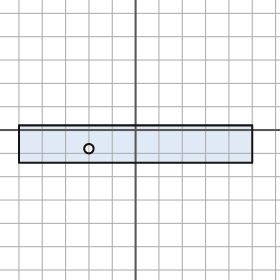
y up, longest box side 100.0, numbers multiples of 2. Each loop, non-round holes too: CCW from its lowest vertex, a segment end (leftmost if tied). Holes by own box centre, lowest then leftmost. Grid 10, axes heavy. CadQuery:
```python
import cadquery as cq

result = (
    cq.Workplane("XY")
    .moveTo(-50.0, -14.0)
    .lineTo(50.0, -14.0)
    .lineTo(50.0, 2.0)
    .lineTo(-50.0, 2.0)
    .close()
    .moveTo(-20.0, -8.0)
    .circle(2.0)
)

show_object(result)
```